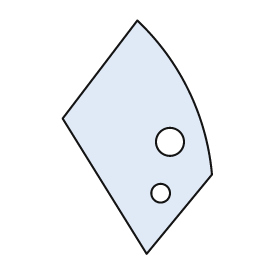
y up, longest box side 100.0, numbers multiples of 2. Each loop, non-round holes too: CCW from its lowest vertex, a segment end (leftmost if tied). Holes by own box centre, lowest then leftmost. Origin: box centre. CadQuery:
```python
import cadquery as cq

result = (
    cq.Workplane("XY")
    .moveTo(4.0, -50.0)
    .lineTo(32.0, -16.0)
    .threePointArc((22.0, 20.0), (0.0, 50.0))
    .lineTo(-32.0, 8.0)
    .close()
    .moveTo(10.0, -24.0)
    .circle(4.0)
    .moveTo(14.0, -2.0)
    .circle(6.0)
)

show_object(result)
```